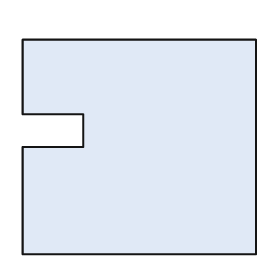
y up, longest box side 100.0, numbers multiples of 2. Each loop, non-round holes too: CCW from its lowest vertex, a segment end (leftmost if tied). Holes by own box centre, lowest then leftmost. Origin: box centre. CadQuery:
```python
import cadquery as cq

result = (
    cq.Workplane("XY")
    .moveTo(-50.0, -46.0)
    .lineTo(50.0, -46.0)
    .lineTo(50.0, 46.0)
    .lineTo(-50.0, 46.0)
    .lineTo(-50.0, 14.0)
    .lineTo(-24.0, 14.0)
    .lineTo(-24.0, 0.0)
    .lineTo(-50.0, 0.0)
    .close()
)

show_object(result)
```